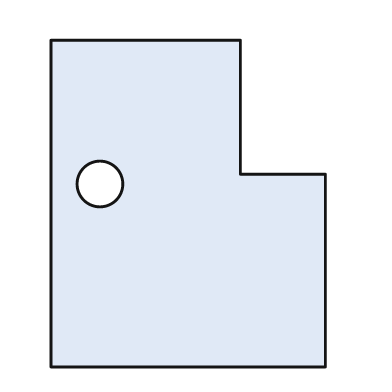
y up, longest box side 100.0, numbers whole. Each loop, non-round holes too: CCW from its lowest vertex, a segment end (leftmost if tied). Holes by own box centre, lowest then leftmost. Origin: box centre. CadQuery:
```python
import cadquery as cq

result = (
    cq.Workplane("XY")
    .moveTo(-42.0, -50.0)
    .lineTo(42.0, -50.0)
    .lineTo(42.0, 9.0)
    .lineTo(16.0, 9.0)
    .lineTo(16.0, 50.0)
    .lineTo(-42.0, 50.0)
    .close()
    .moveTo(-27.0, 6.0)
    .circle(7.0)
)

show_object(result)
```